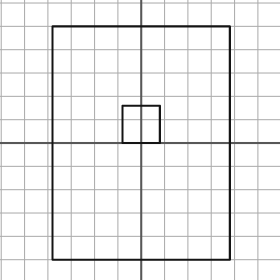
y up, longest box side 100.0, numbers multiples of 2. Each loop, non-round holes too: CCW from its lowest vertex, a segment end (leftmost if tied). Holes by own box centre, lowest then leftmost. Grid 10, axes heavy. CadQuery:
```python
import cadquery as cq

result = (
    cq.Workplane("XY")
    .moveTo(-38.0, -50.0)
    .lineTo(38.0, -50.0)
    .lineTo(38.0, 50.0)
    .lineTo(-38.0, 50.0)
    .close()
    .moveTo(-8.0, 0.0)
    .lineTo(8.0, 0.0)
    .lineTo(8.0, 16.0)
    .lineTo(-8.0, 16.0)
    .close()
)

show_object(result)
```